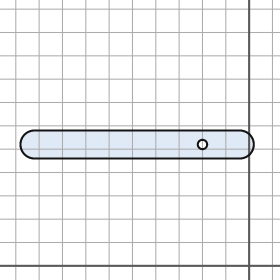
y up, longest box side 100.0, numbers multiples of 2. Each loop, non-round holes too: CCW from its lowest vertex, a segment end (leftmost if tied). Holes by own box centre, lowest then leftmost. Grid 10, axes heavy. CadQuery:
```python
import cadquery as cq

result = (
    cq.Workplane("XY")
    .moveTo(-92.0, 46.0)
    .lineTo(-4.0, 46.0)
    .threePointArc((2.0, 52.0), (-4.0, 58.0))
    .lineTo(-92.0, 58.0)
    .threePointArc((-98.0, 52.0), (-92.0, 46.0))
    .close()
    .moveTo(-20.0, 52.0)
    .circle(2.0)
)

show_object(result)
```